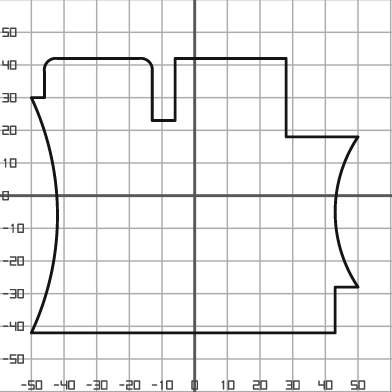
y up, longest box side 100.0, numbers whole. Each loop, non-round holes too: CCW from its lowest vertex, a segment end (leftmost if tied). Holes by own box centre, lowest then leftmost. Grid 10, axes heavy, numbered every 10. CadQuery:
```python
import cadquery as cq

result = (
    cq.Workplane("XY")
    .moveTo(-50.0, -42.0)
    .lineTo(43.0, -42.0)
    .lineTo(43.0, -28.0)
    .lineTo(50.0, -28.0)
    .threePointArc((43.0, -5.0), (50.0, 18.0))
    .lineTo(28.0, 18.0)
    .lineTo(28.0, 42.0)
    .lineTo(-6.0, 42.0)
    .lineTo(-6.0, 23.0)
    .lineTo(-13.0, 23.0)
    .lineTo(-13.0, 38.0)
    .threePointArc((-14.0, 41.0), (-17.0, 42.0))
    .lineTo(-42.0, 42.0)
    .threePointArc((-45.0, 41.0), (-46.0, 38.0))
    .lineTo(-46.0, 30.0)
    .lineTo(-50.0, 30.0)
    .threePointArc((-42.0, -6.0), (-50.0, -42.0))
    .close()
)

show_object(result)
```